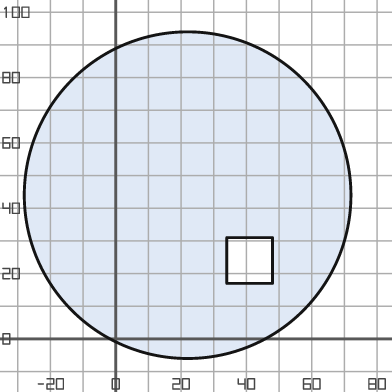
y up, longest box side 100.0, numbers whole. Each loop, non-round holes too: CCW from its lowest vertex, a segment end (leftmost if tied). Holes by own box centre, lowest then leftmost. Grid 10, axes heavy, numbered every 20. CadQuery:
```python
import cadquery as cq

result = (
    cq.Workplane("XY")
    .moveTo(22.0, 44.0)
    .circle(50.0)
    .moveTo(34.0, 17.0)
    .lineTo(48.0, 17.0)
    .lineTo(48.0, 31.0)
    .lineTo(34.0, 31.0)
    .close()
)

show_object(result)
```